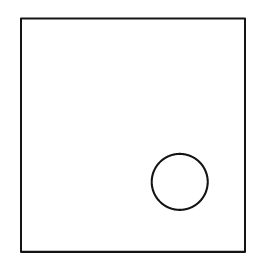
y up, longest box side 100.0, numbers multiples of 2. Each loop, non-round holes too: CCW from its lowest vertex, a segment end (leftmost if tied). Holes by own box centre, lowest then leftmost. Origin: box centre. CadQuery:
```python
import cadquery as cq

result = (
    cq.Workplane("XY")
    .moveTo(-48.0, -50.0)
    .lineTo(48.0, -50.0)
    .lineTo(48.0, 50.0)
    .lineTo(-48.0, 50.0)
    .close()
    .moveTo(20.0, -20.0)
    .circle(12.0)
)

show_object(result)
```